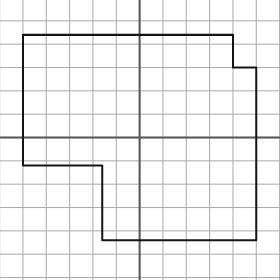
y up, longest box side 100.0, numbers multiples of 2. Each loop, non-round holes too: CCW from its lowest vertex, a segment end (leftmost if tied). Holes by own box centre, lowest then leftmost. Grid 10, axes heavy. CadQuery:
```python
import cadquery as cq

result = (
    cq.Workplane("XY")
    .moveTo(-16.0, -44.0)
    .lineTo(50.0, -44.0)
    .lineTo(50.0, 30.0)
    .lineTo(40.0, 30.0)
    .lineTo(40.0, 44.0)
    .lineTo(-50.0, 44.0)
    .lineTo(-50.0, -12.0)
    .lineTo(-16.0, -12.0)
    .close()
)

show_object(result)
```